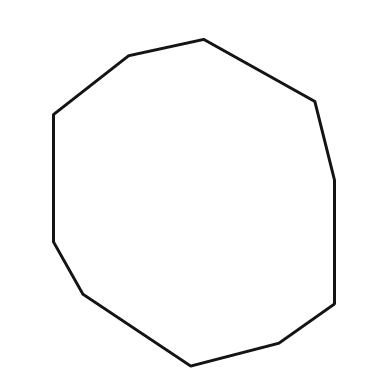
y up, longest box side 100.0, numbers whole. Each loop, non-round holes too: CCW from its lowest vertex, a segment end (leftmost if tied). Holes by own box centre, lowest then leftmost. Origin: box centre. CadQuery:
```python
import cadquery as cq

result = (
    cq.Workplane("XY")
    .moveTo(-1.0, -50.0)
    .lineTo(26.0, -43.0)
    .lineTo(43.0, -31.0)
    .lineTo(43.0, 7.0)
    .lineTo(37.0, 31.0)
    .lineTo(3.0, 50.0)
    .lineTo(-20.0, 45.0)
    .lineTo(-43.0, 27.0)
    .lineTo(-43.0, -12.0)
    .lineTo(-34.0, -28.0)
    .close()
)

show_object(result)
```